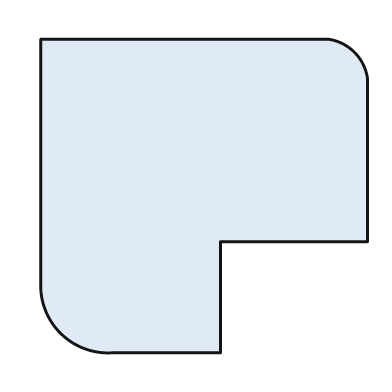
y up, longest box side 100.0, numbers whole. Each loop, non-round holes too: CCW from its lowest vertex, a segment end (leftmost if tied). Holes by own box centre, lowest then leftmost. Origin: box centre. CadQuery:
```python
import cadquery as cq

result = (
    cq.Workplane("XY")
    .moveTo(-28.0, -48.0)
    .lineTo(5.0, -48.0)
    .lineTo(5.0, -14.0)
    .lineTo(50.0, -14.0)
    .lineTo(50.0, 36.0)
    .threePointArc((46.0, 44.0), (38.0, 48.0))
    .lineTo(-50.0, 48.0)
    .lineTo(-50.0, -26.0)
    .threePointArc((-44.0, -42.0), (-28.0, -48.0))
    .close()
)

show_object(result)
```